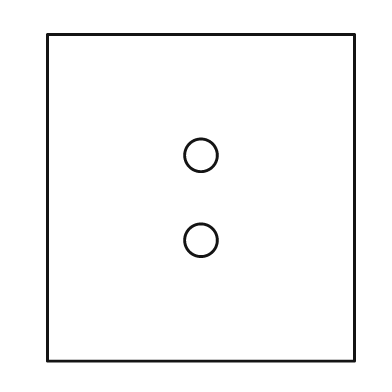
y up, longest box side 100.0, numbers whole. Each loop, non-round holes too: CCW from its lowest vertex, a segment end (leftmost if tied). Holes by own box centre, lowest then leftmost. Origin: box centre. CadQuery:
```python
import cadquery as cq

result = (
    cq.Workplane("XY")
    .moveTo(-47.0, -50.0)
    .lineTo(47.0, -50.0)
    .lineTo(47.0, 50.0)
    .lineTo(-47.0, 50.0)
    .close()
    .moveTo(0.0, -13.0)
    .circle(5.0)
    .moveTo(0.0, 13.0)
    .circle(5.0)
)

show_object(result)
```